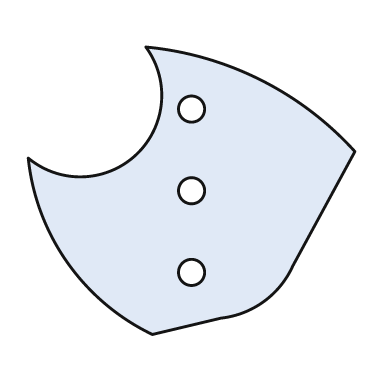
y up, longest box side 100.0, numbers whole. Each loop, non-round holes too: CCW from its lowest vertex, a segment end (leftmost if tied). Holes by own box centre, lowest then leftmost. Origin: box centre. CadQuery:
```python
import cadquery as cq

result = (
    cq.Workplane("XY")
    .moveTo(-12.0, -44.0)
    .lineTo(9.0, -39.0)
    .threePointArc((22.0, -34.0), (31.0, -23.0))
    .lineTo(50.0, 12.0)
    .threePointArc((21.0, 34.0), (-14.0, 44.0))
    .threePointArc((-17.0, 11.0), (-50.0, 10.0))
    .threePointArc((-38.0, -22.0), (-12.0, -44.0))
    .close()
    .moveTo(0.0, -25.0)
    .circle(4.0)
    .moveTo(0.0, 0.0)
    .circle(4.0)
    .moveTo(0.0, 25.0)
    .circle(4.0)
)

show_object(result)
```